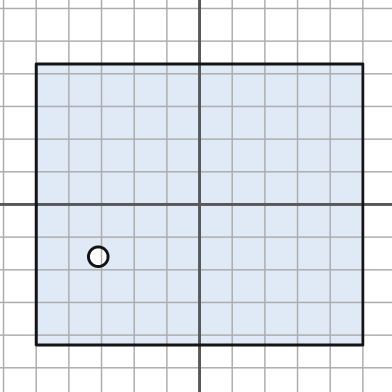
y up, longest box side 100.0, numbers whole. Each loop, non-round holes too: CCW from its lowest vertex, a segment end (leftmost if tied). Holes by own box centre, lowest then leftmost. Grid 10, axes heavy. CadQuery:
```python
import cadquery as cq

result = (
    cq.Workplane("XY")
    .moveTo(-50.0, -43.0)
    .lineTo(50.0, -43.0)
    .lineTo(50.0, 43.0)
    .lineTo(-50.0, 43.0)
    .close()
    .moveTo(-31.0, -16.0)
    .circle(3.0)
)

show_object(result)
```